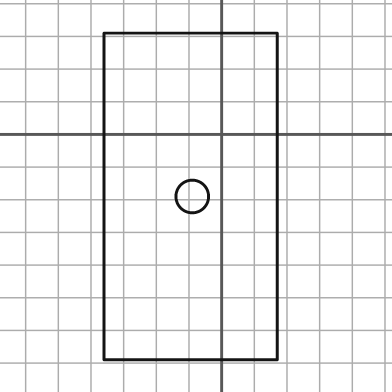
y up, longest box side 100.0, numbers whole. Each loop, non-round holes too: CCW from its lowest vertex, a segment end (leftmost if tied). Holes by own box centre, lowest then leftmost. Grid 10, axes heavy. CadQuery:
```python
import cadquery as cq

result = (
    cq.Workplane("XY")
    .moveTo(-36.0, -69.0)
    .lineTo(17.0, -69.0)
    .lineTo(17.0, 31.0)
    .lineTo(-36.0, 31.0)
    .close()
    .moveTo(-9.0, -19.0)
    .circle(5.0)
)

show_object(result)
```